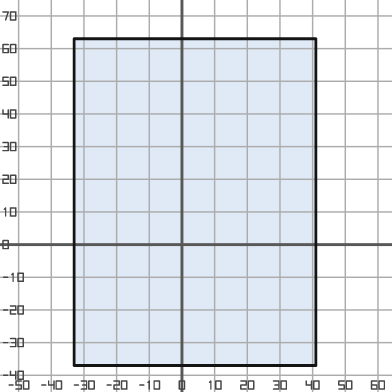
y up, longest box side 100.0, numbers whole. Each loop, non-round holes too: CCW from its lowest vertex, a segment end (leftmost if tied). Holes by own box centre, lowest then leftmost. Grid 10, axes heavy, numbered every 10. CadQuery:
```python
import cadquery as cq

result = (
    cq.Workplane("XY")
    .moveTo(-33.0, -37.0)
    .lineTo(41.0, -37.0)
    .lineTo(41.0, 63.0)
    .lineTo(-33.0, 63.0)
    .close()
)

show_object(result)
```